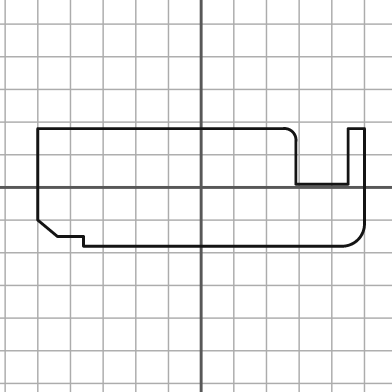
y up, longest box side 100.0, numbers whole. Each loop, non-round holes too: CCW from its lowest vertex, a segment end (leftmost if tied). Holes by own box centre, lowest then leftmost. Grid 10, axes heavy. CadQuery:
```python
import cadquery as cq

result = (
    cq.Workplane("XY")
    .moveTo(-36.0, -18.0)
    .lineTo(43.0, -18.0)
    .threePointArc((48.0, -16.0), (50.0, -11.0))
    .lineTo(50.0, 18.0)
    .lineTo(45.0, 18.0)
    .lineTo(45.0, 1.0)
    .lineTo(29.0, 1.0)
    .lineTo(29.0, 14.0)
    .threePointArc((28.0, 17.0), (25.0, 18.0))
    .lineTo(-50.0, 18.0)
    .lineTo(-50.0, -10.0)
    .lineTo(-44.0, -15.0)
    .lineTo(-36.0, -15.0)
    .close()
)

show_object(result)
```